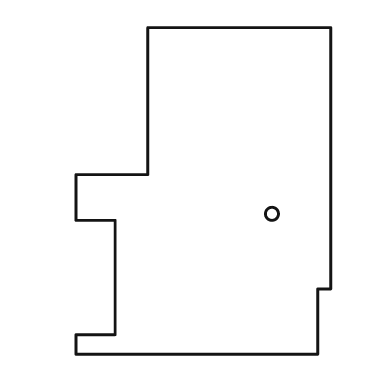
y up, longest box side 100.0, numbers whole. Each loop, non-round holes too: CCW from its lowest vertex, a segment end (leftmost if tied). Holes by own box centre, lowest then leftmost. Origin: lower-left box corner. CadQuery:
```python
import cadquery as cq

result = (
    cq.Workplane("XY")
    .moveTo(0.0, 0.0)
    .lineTo(74.0, 0.0)
    .lineTo(74.0, 20.0)
    .lineTo(78.0, 20.0)
    .lineTo(78.0, 100.0)
    .lineTo(22.0, 100.0)
    .lineTo(22.0, 55.0)
    .lineTo(0.0, 55.0)
    .lineTo(0.0, 41.0)
    .lineTo(12.0, 41.0)
    .lineTo(12.0, 6.0)
    .lineTo(0.0, 6.0)
    .close()
    .moveTo(60.0, 43.0)
    .circle(2.0)
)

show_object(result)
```